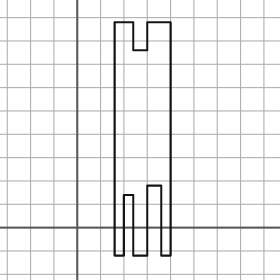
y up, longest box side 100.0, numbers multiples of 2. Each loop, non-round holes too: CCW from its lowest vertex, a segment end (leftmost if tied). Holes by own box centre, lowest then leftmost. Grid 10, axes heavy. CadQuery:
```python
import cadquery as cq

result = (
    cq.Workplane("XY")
    .moveTo(16.0, -12.0)
    .lineTo(20.0, -12.0)
    .lineTo(20.0, 14.0)
    .lineTo(24.0, 14.0)
    .lineTo(24.0, -12.0)
    .lineTo(30.0, -12.0)
    .lineTo(30.0, 18.0)
    .lineTo(36.0, 18.0)
    .lineTo(36.0, -12.0)
    .lineTo(40.0, -12.0)
    .lineTo(40.0, 88.0)
    .lineTo(30.0, 88.0)
    .lineTo(30.0, 76.0)
    .lineTo(24.0, 76.0)
    .lineTo(24.0, 88.0)
    .lineTo(16.0, 88.0)
    .close()
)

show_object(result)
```